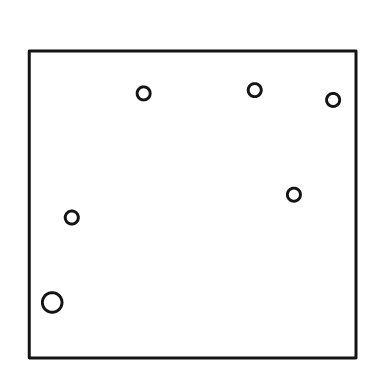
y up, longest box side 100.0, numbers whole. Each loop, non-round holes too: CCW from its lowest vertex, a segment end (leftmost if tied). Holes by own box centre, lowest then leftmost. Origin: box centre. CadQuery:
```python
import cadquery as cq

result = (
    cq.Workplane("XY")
    .moveTo(-50.0, -47.0)
    .lineTo(50.0, -47.0)
    .lineTo(50.0, 47.0)
    .lineTo(-50.0, 47.0)
    .close()
    .moveTo(-43.0, -30.0)
    .circle(3.0)
    .moveTo(-37.0, -4.0)
    .circle(2.0)
    .moveTo(31.0, 3.0)
    .circle(2.0)
    .moveTo(43.0, 32.0)
    .circle(2.0)
    .moveTo(-15.0, 34.0)
    .circle(2.0)
    .moveTo(19.0, 35.0)
    .circle(2.0)
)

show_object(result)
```